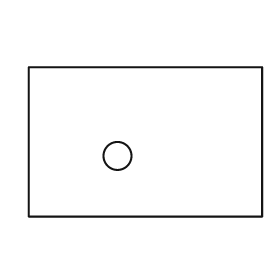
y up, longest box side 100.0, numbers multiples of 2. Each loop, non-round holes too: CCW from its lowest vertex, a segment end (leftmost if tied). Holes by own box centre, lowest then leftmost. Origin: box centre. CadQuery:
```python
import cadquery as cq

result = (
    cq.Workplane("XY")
    .moveTo(-50.0, -32.0)
    .lineTo(50.0, -32.0)
    .lineTo(50.0, 32.0)
    .lineTo(-50.0, 32.0)
    .close()
    .moveTo(-12.0, -6.0)
    .circle(6.0)
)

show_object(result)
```